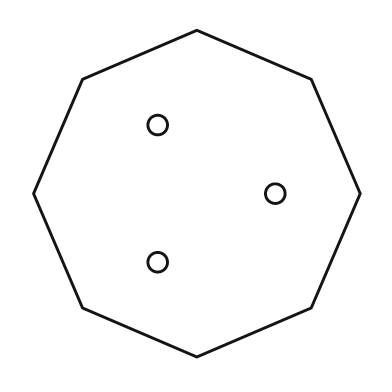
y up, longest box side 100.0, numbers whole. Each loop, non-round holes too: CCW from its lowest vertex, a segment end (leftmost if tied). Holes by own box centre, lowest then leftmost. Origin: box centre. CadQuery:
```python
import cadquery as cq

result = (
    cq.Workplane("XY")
    .moveTo(0.0, -50.0)
    .lineTo(35.0, -35.0)
    .lineTo(50.0, 0.0)
    .lineTo(35.0, 35.0)
    .lineTo(0.0, 50.0)
    .lineTo(-35.0, 35.0)
    .lineTo(-50.0, 0.0)
    .lineTo(-35.0, -35.0)
    .close()
    .moveTo(-12.0, -21.0)
    .circle(3.0)
    .moveTo(24.0, 0.0)
    .circle(3.0)
    .moveTo(-12.0, 21.0)
    .circle(3.0)
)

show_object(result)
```